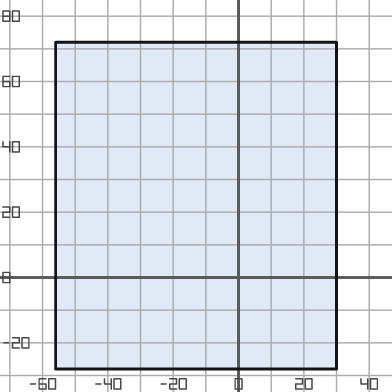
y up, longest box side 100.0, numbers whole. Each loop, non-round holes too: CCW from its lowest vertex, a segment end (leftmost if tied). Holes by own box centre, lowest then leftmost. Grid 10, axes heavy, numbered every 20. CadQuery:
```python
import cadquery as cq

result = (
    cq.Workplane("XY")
    .moveTo(-56.0, -28.0)
    .lineTo(30.0, -28.0)
    .lineTo(30.0, 72.0)
    .lineTo(-56.0, 72.0)
    .close()
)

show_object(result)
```